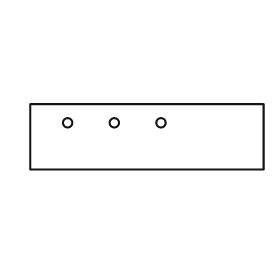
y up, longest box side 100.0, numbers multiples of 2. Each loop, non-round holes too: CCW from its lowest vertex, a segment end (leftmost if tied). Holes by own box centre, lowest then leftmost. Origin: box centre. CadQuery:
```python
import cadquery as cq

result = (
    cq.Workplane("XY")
    .moveTo(-50.0, -14.0)
    .lineTo(50.0, -14.0)
    .lineTo(50.0, 14.0)
    .lineTo(-50.0, 14.0)
    .close()
    .moveTo(-34.0, 6.0)
    .circle(2.0)
    .moveTo(-14.0, 6.0)
    .circle(2.0)
    .moveTo(6.0, 6.0)
    .circle(2.0)
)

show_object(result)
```